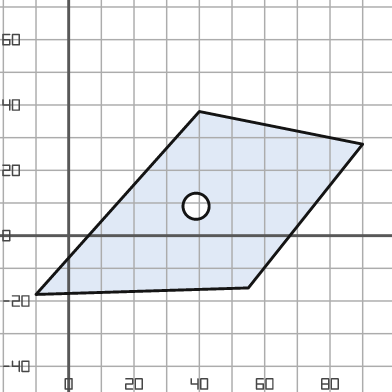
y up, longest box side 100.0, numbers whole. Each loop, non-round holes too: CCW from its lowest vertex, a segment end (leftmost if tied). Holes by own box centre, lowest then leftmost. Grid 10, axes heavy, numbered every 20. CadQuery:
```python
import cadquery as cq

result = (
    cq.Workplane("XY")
    .moveTo(-10.0, -18.0)
    .lineTo(55.0, -16.0)
    .lineTo(90.0, 28.0)
    .lineTo(40.0, 38.0)
    .close()
    .moveTo(39.0, 9.0)
    .circle(4.0)
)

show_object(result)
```